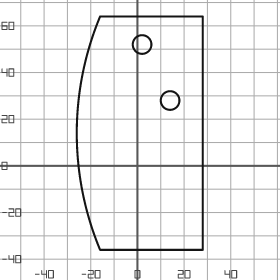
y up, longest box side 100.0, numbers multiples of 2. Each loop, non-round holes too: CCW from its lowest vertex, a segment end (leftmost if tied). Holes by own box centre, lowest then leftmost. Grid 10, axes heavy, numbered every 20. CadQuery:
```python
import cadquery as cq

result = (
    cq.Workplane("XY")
    .moveTo(-16.0, -36.0)
    .lineTo(28.0, -36.0)
    .lineTo(28.0, 64.0)
    .lineTo(-16.0, 64.0)
    .threePointArc((-26.0, 14.0), (-16.0, -36.0))
    .close()
    .moveTo(14.0, 28.0)
    .circle(4.0)
    .moveTo(2.0, 52.0)
    .circle(4.0)
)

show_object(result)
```